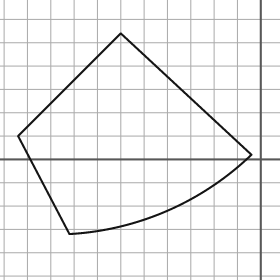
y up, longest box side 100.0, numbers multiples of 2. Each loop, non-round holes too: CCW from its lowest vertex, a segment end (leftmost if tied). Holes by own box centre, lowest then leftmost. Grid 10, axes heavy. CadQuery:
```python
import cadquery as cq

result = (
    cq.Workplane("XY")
    .moveTo(-82.0, -32.0)
    .threePointArc((-40.0, -22.0), (-4.0, 2.0))
    .lineTo(-60.0, 54.0)
    .lineTo(-104.0, 10.0)
    .close()
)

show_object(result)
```